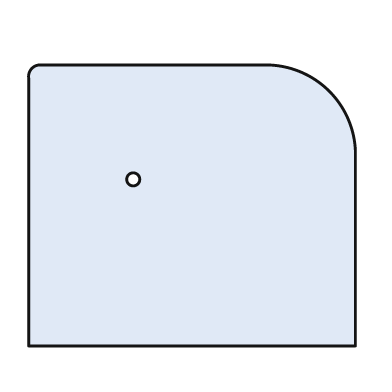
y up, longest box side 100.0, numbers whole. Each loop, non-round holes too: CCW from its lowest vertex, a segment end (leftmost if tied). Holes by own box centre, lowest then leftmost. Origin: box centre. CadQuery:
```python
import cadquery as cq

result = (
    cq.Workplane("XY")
    .moveTo(-50.0, -43.0)
    .lineTo(50.0, -43.0)
    .lineTo(50.0, 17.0)
    .threePointArc((42.0, 35.0), (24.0, 43.0))
    .lineTo(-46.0, 43.0)
    .threePointArc((-49.0, 42.0), (-50.0, 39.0))
    .close()
    .moveTo(-18.0, 8.0)
    .circle(2.0)
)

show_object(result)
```